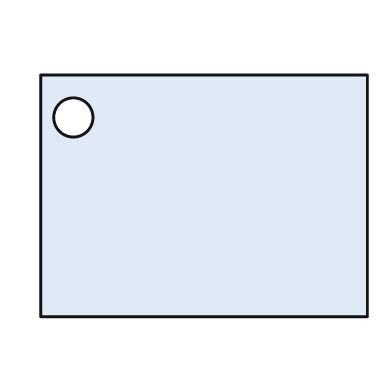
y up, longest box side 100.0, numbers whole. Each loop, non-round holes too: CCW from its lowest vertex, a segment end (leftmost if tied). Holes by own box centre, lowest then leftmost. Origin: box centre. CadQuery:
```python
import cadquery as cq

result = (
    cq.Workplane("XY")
    .moveTo(-50.0, -37.0)
    .lineTo(50.0, -37.0)
    .lineTo(50.0, 37.0)
    .lineTo(-50.0, 37.0)
    .close()
    .moveTo(-40.0, 24.0)
    .circle(6.0)
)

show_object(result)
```